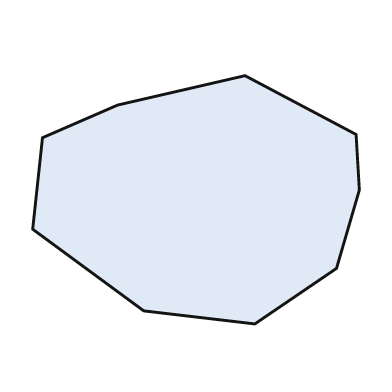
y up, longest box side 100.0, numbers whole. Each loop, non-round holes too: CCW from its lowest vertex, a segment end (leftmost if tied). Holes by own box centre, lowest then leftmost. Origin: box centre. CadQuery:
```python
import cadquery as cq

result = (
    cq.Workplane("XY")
    .moveTo(18.0, -38.0)
    .lineTo(43.0, -21.0)
    .lineTo(50.0, 3.0)
    .lineTo(49.0, 20.0)
    .lineTo(15.0, 38.0)
    .lineTo(-24.0, 29.0)
    .lineTo(-47.0, 19.0)
    .lineTo(-50.0, -9.0)
    .lineTo(-16.0, -34.0)
    .close()
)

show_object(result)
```